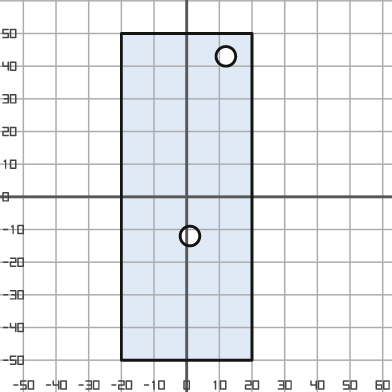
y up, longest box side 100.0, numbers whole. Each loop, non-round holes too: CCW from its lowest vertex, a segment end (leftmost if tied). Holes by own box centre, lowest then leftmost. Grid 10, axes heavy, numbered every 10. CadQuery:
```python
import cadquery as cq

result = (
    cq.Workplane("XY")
    .moveTo(-20.0, -50.0)
    .lineTo(20.0, -50.0)
    .lineTo(20.0, 50.0)
    .lineTo(-20.0, 50.0)
    .close()
    .moveTo(1.0, -12.0)
    .circle(3.0)
    .moveTo(12.0, 43.0)
    .circle(3.0)
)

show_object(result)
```